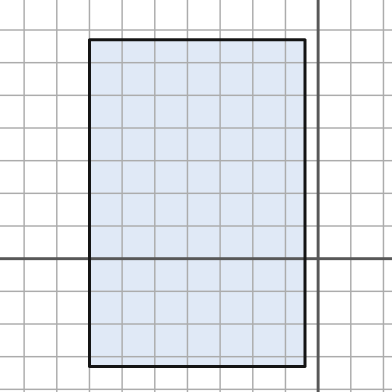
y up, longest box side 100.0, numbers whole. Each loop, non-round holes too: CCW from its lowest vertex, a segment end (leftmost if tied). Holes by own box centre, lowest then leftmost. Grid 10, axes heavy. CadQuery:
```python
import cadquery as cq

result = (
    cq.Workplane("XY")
    .moveTo(-70.0, -33.0)
    .lineTo(-4.0, -33.0)
    .lineTo(-4.0, 67.0)
    .lineTo(-70.0, 67.0)
    .close()
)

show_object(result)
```